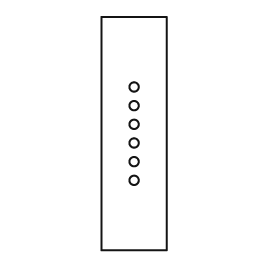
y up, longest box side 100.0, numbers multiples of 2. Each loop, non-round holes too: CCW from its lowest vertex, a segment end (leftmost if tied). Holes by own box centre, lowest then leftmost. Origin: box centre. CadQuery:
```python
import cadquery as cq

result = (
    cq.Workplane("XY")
    .moveTo(-14.0, -50.0)
    .lineTo(14.0, -50.0)
    .lineTo(14.0, 50.0)
    .lineTo(-14.0, 50.0)
    .close()
    .moveTo(0.0, -20.0)
    .circle(2.0)
    .moveTo(0.0, -12.0)
    .circle(2.0)
    .moveTo(0.0, -4.0)
    .circle(2.0)
    .moveTo(0.0, 4.0)
    .circle(2.0)
    .moveTo(0.0, 12.0)
    .circle(2.0)
    .moveTo(0.0, 20.0)
    .circle(2.0)
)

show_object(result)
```